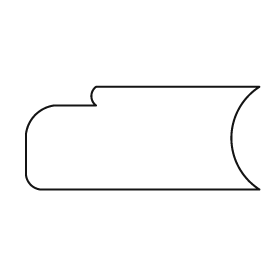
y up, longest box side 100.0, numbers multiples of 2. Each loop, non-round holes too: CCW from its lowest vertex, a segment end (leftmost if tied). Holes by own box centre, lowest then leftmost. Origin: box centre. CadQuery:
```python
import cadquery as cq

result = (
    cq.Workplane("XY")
    .moveTo(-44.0, -22.0)
    .lineTo(50.0, -22.0)
    .threePointArc((38.0, 0.0), (50.0, 22.0))
    .lineTo(-20.0, 22.0)
    .threePointArc((-22.0, 18.0), (-20.0, 14.0))
    .lineTo(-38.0, 14.0)
    .threePointArc((-46.0, 10.0), (-50.0, 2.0))
    .lineTo(-50.0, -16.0)
    .threePointArc((-48.0, -20.0), (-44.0, -22.0))
    .close()
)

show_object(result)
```